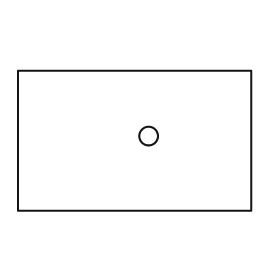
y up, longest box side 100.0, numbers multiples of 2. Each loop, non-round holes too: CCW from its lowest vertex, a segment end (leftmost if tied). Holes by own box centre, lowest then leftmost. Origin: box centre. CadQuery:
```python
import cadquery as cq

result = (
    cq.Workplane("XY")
    .moveTo(-50.0, -30.0)
    .lineTo(50.0, -30.0)
    .lineTo(50.0, 30.0)
    .lineTo(-50.0, 30.0)
    .close()
    .moveTo(6.0, 2.0)
    .circle(4.0)
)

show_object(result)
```